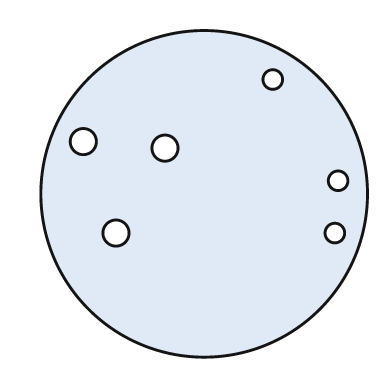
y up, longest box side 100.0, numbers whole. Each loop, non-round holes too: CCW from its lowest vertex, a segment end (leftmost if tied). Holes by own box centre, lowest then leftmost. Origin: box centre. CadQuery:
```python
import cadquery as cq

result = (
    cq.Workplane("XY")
    .moveTo(0.0, 0.0)
    .circle(50.0)
    .moveTo(-27.0, -12.0)
    .circle(4.0)
    .moveTo(40.0, -12.0)
    .circle(3.0)
    .moveTo(41.0, 4.0)
    .circle(3.0)
    .moveTo(-12.0, 14.0)
    .circle(4.0)
    .moveTo(-37.0, 16.0)
    .circle(4.0)
    .moveTo(21.0, 35.0)
    .circle(3.0)
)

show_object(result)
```